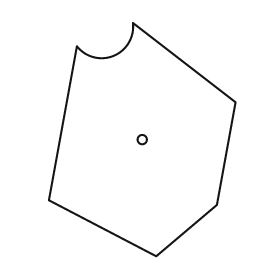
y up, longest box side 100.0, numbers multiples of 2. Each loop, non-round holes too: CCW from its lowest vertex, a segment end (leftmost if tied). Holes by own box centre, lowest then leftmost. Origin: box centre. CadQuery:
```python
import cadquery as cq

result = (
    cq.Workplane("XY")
    .moveTo(6.0, -50.0)
    .lineTo(32.0, -28.0)
    .lineTo(40.0, 16.0)
    .lineTo(-4.0, 50.0)
    .threePointArc((-12.0, 36.0), (-28.0, 40.0))
    .lineTo(-40.0, -26.0)
    .close()
    .moveTo(0.0, 0.0)
    .circle(2.0)
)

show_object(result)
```